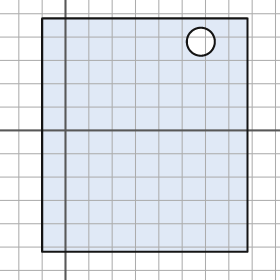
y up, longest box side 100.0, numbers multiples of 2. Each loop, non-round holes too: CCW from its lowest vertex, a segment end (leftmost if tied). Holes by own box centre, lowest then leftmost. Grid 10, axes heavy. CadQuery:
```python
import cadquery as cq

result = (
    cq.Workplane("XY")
    .moveTo(-10.0, -52.0)
    .lineTo(78.0, -52.0)
    .lineTo(78.0, 48.0)
    .lineTo(-10.0, 48.0)
    .close()
    .moveTo(58.0, 38.0)
    .circle(6.0)
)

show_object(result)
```